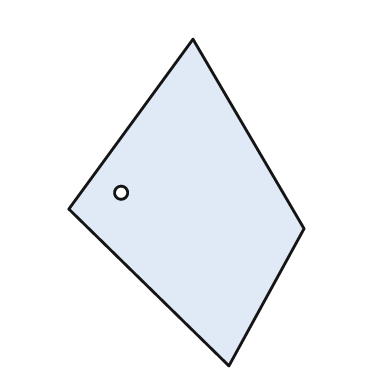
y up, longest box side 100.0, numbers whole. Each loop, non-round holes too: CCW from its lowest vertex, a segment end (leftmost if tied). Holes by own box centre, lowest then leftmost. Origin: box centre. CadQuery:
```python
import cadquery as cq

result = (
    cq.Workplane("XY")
    .moveTo(13.0, -50.0)
    .lineTo(36.0, -8.0)
    .lineTo(2.0, 50.0)
    .lineTo(-36.0, -2.0)
    .close()
    .moveTo(-20.0, 3.0)
    .circle(2.0)
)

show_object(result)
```